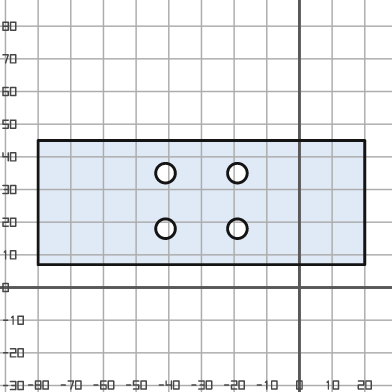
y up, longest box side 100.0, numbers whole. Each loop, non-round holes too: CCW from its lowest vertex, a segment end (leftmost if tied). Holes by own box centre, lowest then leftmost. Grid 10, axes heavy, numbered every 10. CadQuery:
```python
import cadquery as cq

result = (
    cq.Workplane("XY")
    .moveTo(-80.0, 7.0)
    .lineTo(20.0, 7.0)
    .lineTo(20.0, 45.0)
    .lineTo(-80.0, 45.0)
    .close()
    .moveTo(-41.0, 18.0)
    .circle(3.0)
    .moveTo(-19.0, 18.0)
    .circle(3.0)
    .moveTo(-41.0, 35.0)
    .circle(3.0)
    .moveTo(-19.0, 35.0)
    .circle(3.0)
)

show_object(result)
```